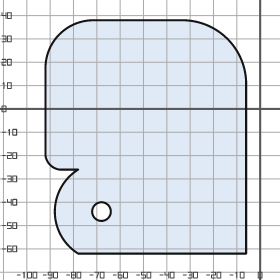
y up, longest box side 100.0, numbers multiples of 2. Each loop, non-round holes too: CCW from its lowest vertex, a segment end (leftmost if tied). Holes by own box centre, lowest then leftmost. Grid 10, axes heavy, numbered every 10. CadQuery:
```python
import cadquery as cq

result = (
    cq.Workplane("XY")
    .moveTo(-78.0, -62.0)
    .lineTo(-6.0, -62.0)
    .lineTo(-6.0, 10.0)
    .threePointArc((-14.0, 30.0), (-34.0, 38.0))
    .lineTo(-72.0, 38.0)
    .threePointArc((-86.0, 32.0), (-92.0, 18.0))
    .lineTo(-92.0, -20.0)
    .threePointArc((-90.0, -24.0), (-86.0, -26.0))
    .lineTo(-78.0, -26.0)
    .threePointArc((-88.0, -44.0), (-78.0, -62.0))
    .close()
    .moveTo(-68.0, -44.0)
    .circle(4.0)
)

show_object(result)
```